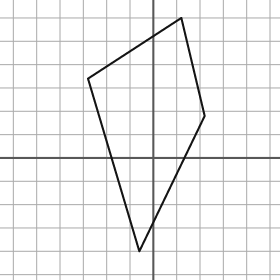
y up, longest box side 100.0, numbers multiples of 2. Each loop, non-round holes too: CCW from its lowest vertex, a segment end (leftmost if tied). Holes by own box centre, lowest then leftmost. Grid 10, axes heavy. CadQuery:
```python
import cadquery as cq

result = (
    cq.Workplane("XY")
    .moveTo(-6.0, -40.0)
    .lineTo(22.0, 18.0)
    .lineTo(12.0, 60.0)
    .lineTo(-28.0, 34.0)
    .close()
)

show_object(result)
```